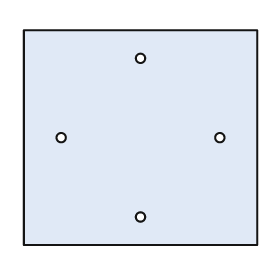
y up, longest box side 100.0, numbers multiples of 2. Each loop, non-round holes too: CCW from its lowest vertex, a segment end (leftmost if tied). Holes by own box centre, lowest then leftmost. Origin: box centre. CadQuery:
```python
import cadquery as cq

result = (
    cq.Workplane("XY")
    .moveTo(-50.0, -46.0)
    .lineTo(50.0, -46.0)
    .lineTo(50.0, 46.0)
    .lineTo(-50.0, 46.0)
    .close()
    .moveTo(0.0, -34.0)
    .circle(2.0)
    .moveTo(-34.0, 0.0)
    .circle(2.0)
    .moveTo(34.0, 0.0)
    .circle(2.0)
    .moveTo(0.0, 34.0)
    .circle(2.0)
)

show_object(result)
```